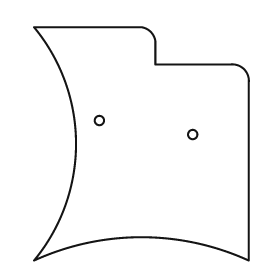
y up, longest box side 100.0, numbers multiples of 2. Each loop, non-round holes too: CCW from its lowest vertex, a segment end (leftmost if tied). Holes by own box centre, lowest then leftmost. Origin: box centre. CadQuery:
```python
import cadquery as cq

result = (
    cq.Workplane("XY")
    .moveTo(-46.0, -50.0)
    .threePointArc((0.0, -40.0), (46.0, -50.0))
    .lineTo(46.0, 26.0)
    .threePointArc((44.0, 32.0), (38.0, 34.0))
    .lineTo(6.0, 34.0)
    .lineTo(6.0, 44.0)
    .threePointArc((4.0, 48.0), (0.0, 50.0))
    .lineTo(-46.0, 50.0)
    .threePointArc((-28.0, 0.0), (-46.0, -50.0))
    .close()
    .moveTo(22.0, 4.0)
    .circle(2.0)
    .moveTo(-18.0, 10.0)
    .circle(2.0)
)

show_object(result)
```